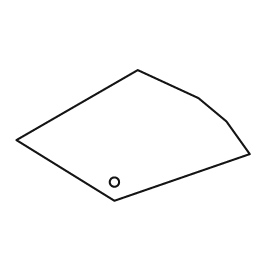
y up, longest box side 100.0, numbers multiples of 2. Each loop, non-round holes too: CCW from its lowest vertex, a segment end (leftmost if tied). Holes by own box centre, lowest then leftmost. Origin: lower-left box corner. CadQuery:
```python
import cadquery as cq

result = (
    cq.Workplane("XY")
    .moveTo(42.0, 0.0)
    .lineTo(100.0, 20.0)
    .lineTo(90.0, 34.0)
    .lineTo(78.0, 44.0)
    .lineTo(52.0, 56.0)
    .lineTo(0.0, 26.0)
    .close()
    .moveTo(42.0, 8.0)
    .circle(2.0)
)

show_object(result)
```